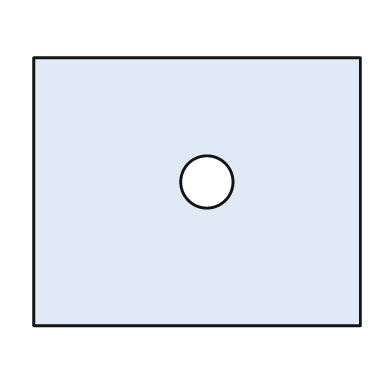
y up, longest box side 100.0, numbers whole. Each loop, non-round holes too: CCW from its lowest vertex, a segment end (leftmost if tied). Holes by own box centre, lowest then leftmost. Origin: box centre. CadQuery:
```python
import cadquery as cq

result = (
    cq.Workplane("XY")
    .moveTo(-50.0, -41.0)
    .lineTo(50.0, -41.0)
    .lineTo(50.0, 41.0)
    .lineTo(-50.0, 41.0)
    .close()
    .moveTo(3.0, 3.0)
    .circle(8.0)
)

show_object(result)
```